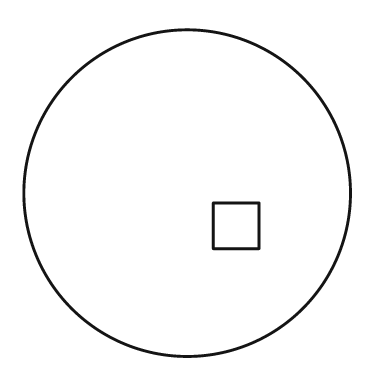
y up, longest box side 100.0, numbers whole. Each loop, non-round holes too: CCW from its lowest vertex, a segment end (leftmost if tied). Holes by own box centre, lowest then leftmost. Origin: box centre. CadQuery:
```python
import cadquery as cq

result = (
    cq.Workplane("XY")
    .moveTo(0.0, 0.0)
    .circle(50.0)
    .moveTo(8.0, -17.0)
    .lineTo(22.0, -17.0)
    .lineTo(22.0, -3.0)
    .lineTo(8.0, -3.0)
    .close()
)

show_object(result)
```